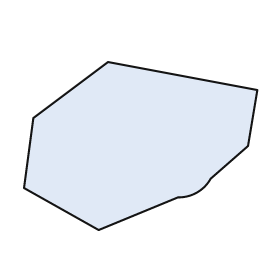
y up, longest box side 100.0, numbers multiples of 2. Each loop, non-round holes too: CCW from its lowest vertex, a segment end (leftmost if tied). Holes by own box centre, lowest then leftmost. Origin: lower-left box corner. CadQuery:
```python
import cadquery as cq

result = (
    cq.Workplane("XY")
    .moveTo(32.0, 0.0)
    .lineTo(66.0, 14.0)
    .threePointArc((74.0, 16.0), (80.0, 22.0))
    .lineTo(96.0, 36.0)
    .lineTo(100.0, 60.0)
    .lineTo(36.0, 72.0)
    .lineTo(4.0, 48.0)
    .lineTo(0.0, 18.0)
    .close()
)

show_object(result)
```